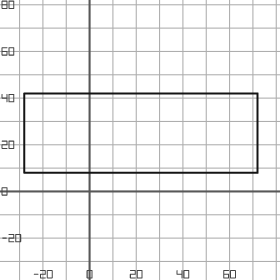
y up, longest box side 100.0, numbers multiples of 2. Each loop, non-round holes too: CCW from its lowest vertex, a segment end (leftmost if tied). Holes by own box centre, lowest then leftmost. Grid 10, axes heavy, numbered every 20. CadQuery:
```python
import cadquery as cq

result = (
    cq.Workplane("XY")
    .moveTo(-28.0, 8.0)
    .lineTo(72.0, 8.0)
    .lineTo(72.0, 42.0)
    .lineTo(-28.0, 42.0)
    .close()
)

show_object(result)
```